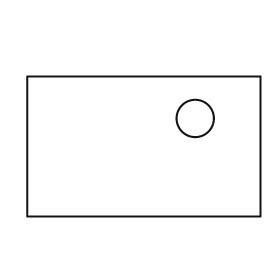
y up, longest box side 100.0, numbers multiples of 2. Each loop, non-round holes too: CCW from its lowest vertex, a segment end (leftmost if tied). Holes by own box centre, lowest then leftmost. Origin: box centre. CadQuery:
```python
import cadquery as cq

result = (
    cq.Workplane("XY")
    .moveTo(-50.0, -30.0)
    .lineTo(50.0, -30.0)
    .lineTo(50.0, 30.0)
    .lineTo(-50.0, 30.0)
    .close()
    .moveTo(22.0, 12.0)
    .circle(8.0)
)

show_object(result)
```